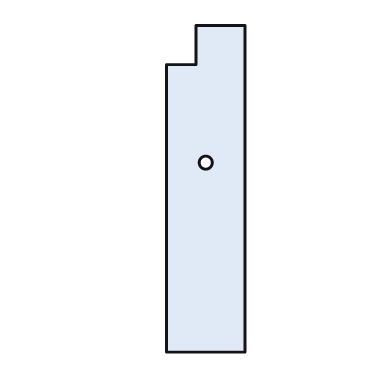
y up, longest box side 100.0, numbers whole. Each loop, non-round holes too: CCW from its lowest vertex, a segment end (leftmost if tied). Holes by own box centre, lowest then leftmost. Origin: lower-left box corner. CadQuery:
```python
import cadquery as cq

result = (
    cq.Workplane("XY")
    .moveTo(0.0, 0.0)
    .lineTo(24.0, 0.0)
    .lineTo(24.0, 100.0)
    .lineTo(9.0, 100.0)
    .lineTo(9.0, 88.0)
    .lineTo(0.0, 88.0)
    .close()
    .moveTo(12.0, 58.0)
    .circle(2.0)
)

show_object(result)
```